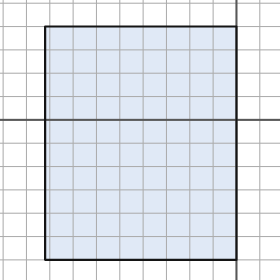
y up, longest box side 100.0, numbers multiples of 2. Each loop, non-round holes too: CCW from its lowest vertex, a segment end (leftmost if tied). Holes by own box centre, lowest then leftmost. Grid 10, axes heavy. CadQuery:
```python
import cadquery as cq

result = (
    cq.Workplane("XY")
    .moveTo(-82.0, -60.0)
    .lineTo(0.0, -60.0)
    .lineTo(0.0, 40.0)
    .lineTo(-82.0, 40.0)
    .close()
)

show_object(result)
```